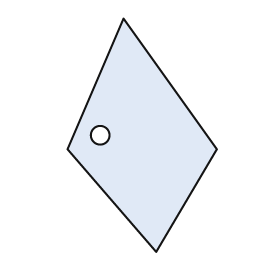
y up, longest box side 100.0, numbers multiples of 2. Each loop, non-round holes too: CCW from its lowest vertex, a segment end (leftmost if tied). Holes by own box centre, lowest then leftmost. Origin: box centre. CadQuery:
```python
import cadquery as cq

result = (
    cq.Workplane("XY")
    .moveTo(6.0, -50.0)
    .lineTo(32.0, -6.0)
    .lineTo(-8.0, 50.0)
    .lineTo(-32.0, -6.0)
    .close()
    .moveTo(-18.0, 0.0)
    .circle(4.0)
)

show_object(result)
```